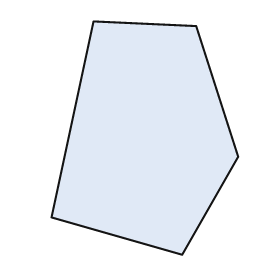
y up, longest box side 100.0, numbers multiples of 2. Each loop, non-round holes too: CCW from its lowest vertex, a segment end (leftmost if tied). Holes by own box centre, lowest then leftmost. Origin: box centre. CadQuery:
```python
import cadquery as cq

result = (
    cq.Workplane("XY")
    .moveTo(16.0, -50.0)
    .lineTo(40.0, -8.0)
    .lineTo(22.0, 48.0)
    .lineTo(-22.0, 50.0)
    .lineTo(-40.0, -34.0)
    .close()
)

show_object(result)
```